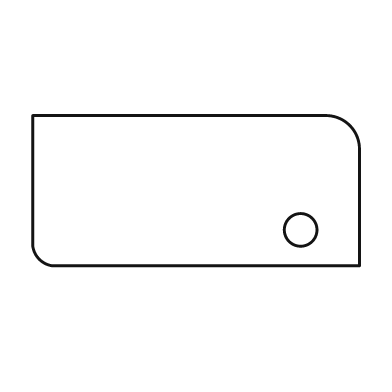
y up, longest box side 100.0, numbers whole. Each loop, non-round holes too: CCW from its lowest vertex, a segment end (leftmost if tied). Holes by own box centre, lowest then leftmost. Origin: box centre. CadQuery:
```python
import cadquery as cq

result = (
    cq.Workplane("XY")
    .moveTo(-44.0, -23.0)
    .lineTo(50.0, -23.0)
    .lineTo(50.0, 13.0)
    .threePointArc((47.0, 20.0), (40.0, 23.0))
    .lineTo(-50.0, 23.0)
    .lineTo(-50.0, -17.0)
    .threePointArc((-48.0, -21.0), (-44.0, -23.0))
    .close()
    .moveTo(32.0, -12.0)
    .circle(5.0)
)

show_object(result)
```